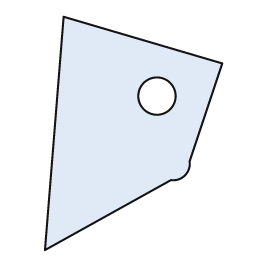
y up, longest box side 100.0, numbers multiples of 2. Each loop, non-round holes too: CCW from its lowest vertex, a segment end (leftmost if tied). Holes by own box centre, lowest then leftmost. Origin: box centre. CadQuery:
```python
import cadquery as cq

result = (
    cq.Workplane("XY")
    .moveTo(-38.0, -50.0)
    .lineTo(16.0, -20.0)
    .threePointArc((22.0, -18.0), (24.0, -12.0))
    .lineTo(38.0, 30.0)
    .lineTo(-30.0, 50.0)
    .close()
    .moveTo(10.0, 16.0)
    .circle(8.0)
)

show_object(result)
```